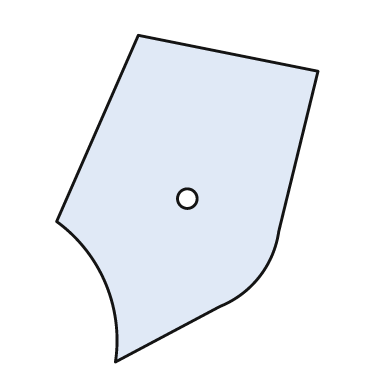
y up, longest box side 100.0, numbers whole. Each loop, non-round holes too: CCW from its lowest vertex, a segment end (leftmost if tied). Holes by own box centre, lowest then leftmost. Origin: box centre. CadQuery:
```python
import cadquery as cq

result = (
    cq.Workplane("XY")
    .moveTo(-22.0, -50.0)
    .lineTo(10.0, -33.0)
    .threePointArc((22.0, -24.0), (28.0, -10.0))
    .lineTo(40.0, 39.0)
    .lineTo(-15.0, 50.0)
    .lineTo(-40.0, -7.0)
    .threePointArc((-25.0, -26.0), (-22.0, -50.0))
    .close()
    .moveTo(0.0, 0.0)
    .circle(3.0)
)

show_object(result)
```